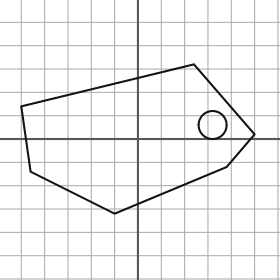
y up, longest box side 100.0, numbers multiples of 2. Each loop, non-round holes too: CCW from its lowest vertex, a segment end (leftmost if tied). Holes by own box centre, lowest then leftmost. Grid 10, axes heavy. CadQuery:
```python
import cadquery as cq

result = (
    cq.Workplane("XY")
    .moveTo(-10.0, -32.0)
    .lineTo(38.0, -12.0)
    .lineTo(50.0, 2.0)
    .lineTo(24.0, 32.0)
    .lineTo(-50.0, 14.0)
    .lineTo(-46.0, -14.0)
    .close()
    .moveTo(32.0, 6.0)
    .circle(6.0)
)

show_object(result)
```